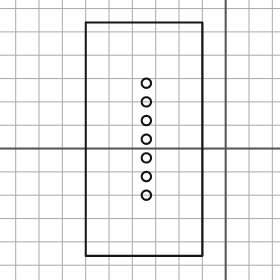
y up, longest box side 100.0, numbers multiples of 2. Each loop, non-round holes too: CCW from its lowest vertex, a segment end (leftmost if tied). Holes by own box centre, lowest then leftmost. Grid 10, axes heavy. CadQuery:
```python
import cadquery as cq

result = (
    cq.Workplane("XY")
    .moveTo(-60.0, -46.0)
    .lineTo(-10.0, -46.0)
    .lineTo(-10.0, 54.0)
    .lineTo(-60.0, 54.0)
    .close()
    .moveTo(-34.0, -20.0)
    .circle(2.0)
    .moveTo(-34.0, -12.0)
    .circle(2.0)
    .moveTo(-34.0, -4.0)
    .circle(2.0)
    .moveTo(-34.0, 4.0)
    .circle(2.0)
    .moveTo(-34.0, 12.0)
    .circle(2.0)
    .moveTo(-34.0, 20.0)
    .circle(2.0)
    .moveTo(-34.0, 28.0)
    .circle(2.0)
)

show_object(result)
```